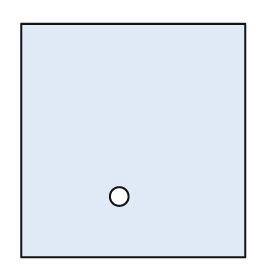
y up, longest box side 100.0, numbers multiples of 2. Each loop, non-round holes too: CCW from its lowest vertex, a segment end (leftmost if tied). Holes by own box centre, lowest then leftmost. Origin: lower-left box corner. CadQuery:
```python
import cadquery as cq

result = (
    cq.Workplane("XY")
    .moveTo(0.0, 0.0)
    .lineTo(96.0, 0.0)
    .lineTo(96.0, 100.0)
    .lineTo(0.0, 100.0)
    .close()
    .moveTo(42.0, 26.0)
    .circle(4.0)
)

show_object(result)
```